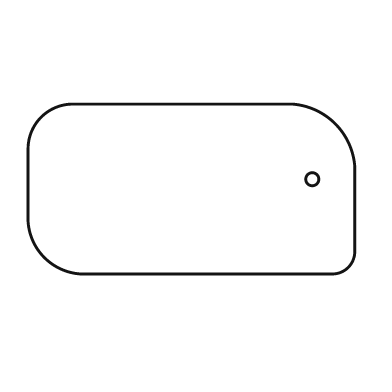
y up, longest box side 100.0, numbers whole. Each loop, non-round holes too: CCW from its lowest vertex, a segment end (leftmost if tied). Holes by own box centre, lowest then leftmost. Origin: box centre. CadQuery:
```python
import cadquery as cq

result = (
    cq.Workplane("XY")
    .moveTo(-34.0, -26.0)
    .lineTo(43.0, -26.0)
    .threePointArc((48.0, -24.0), (50.0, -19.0))
    .lineTo(50.0, 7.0)
    .threePointArc((44.0, 20.0), (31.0, 26.0))
    .lineTo(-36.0, 26.0)
    .threePointArc((-46.0, 22.0), (-50.0, 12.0))
    .lineTo(-50.0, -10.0)
    .threePointArc((-45.0, -21.0), (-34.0, -26.0))
    .close()
    .moveTo(37.0, 3.0)
    .circle(2.0)
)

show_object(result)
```